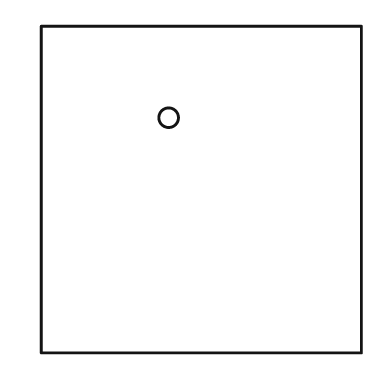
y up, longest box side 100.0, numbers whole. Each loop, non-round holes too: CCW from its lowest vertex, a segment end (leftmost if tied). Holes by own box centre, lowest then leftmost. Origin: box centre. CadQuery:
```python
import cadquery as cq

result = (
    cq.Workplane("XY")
    .moveTo(-49.0, -50.0)
    .lineTo(49.0, -50.0)
    .lineTo(49.0, 50.0)
    .lineTo(-49.0, 50.0)
    .close()
    .moveTo(-10.0, 22.0)
    .circle(3.0)
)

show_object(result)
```